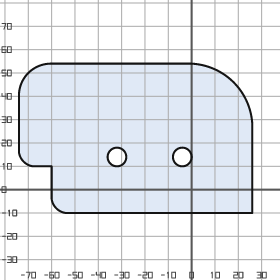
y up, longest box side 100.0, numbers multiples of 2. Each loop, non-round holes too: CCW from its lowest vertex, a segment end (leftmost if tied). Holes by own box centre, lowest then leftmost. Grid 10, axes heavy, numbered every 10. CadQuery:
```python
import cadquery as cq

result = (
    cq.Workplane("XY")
    .moveTo(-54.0, -10.0)
    .lineTo(26.0, -10.0)
    .lineTo(26.0, 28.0)
    .threePointArc((18.0, 46.0), (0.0, 54.0))
    .lineTo(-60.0, 54.0)
    .threePointArc((-70.0, 50.0), (-74.0, 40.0))
    .lineTo(-74.0, 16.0)
    .threePointArc((-72.0, 12.0), (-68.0, 10.0))
    .lineTo(-60.0, 10.0)
    .lineTo(-60.0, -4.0)
    .threePointArc((-58.0, -8.0), (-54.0, -10.0))
    .close()
    .moveTo(-32.0, 14.0)
    .circle(4.0)
    .moveTo(-4.0, 14.0)
    .circle(4.0)
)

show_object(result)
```